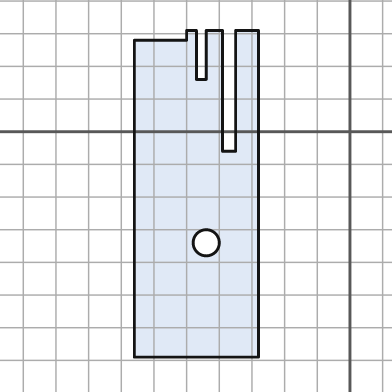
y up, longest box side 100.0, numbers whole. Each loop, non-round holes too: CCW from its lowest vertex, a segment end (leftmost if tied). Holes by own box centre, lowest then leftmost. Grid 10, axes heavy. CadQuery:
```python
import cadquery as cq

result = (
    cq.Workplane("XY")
    .moveTo(-66.0, -69.0)
    .lineTo(-28.0, -69.0)
    .lineTo(-28.0, 31.0)
    .lineTo(-35.0, 31.0)
    .lineTo(-35.0, -6.0)
    .lineTo(-39.0, -6.0)
    .lineTo(-39.0, 31.0)
    .lineTo(-44.0, 31.0)
    .lineTo(-44.0, 16.0)
    .lineTo(-47.0, 16.0)
    .lineTo(-47.0, 31.0)
    .lineTo(-50.0, 31.0)
    .lineTo(-50.0, 28.0)
    .lineTo(-66.0, 28.0)
    .close()
    .moveTo(-44.0, -34.0)
    .circle(4.0)
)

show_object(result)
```